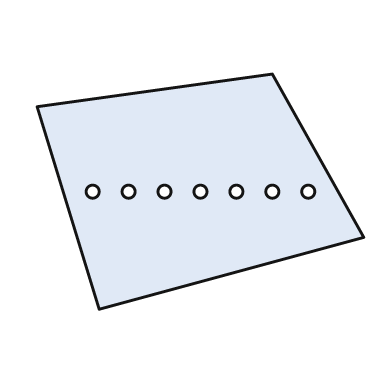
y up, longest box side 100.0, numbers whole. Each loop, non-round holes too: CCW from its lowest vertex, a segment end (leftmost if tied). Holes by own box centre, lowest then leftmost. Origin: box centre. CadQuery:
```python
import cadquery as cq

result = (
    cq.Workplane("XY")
    .moveTo(-31.0, -36.0)
    .lineTo(50.0, -14.0)
    .lineTo(22.0, 36.0)
    .lineTo(-50.0, 26.0)
    .close()
    .moveTo(-33.0, 0.0)
    .circle(2.0)
    .moveTo(-22.0, 0.0)
    .circle(2.0)
    .moveTo(-11.0, 0.0)
    .circle(2.0)
    .moveTo(0.0, 0.0)
    .circle(2.0)
    .moveTo(11.0, 0.0)
    .circle(2.0)
    .moveTo(22.0, 0.0)
    .circle(2.0)
    .moveTo(33.0, 0.0)
    .circle(2.0)
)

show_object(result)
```